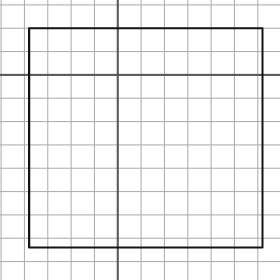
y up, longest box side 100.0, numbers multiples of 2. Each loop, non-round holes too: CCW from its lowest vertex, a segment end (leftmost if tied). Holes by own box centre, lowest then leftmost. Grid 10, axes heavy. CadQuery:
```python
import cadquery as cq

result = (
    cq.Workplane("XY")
    .moveTo(-38.0, -74.0)
    .lineTo(62.0, -74.0)
    .lineTo(62.0, 20.0)
    .lineTo(-38.0, 20.0)
    .close()
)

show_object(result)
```